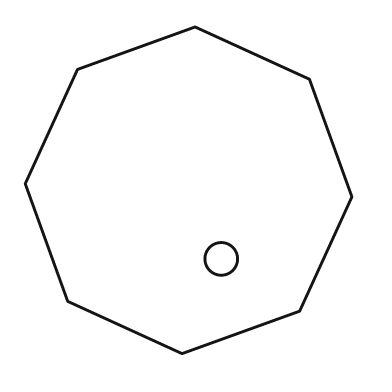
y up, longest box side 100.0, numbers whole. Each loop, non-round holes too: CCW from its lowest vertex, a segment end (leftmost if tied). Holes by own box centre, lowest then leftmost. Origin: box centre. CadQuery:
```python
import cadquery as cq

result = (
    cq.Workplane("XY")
    .moveTo(-2.0, -50.0)
    .lineTo(34.0, -37.0)
    .lineTo(50.0, -2.0)
    .lineTo(37.0, 34.0)
    .lineTo(2.0, 50.0)
    .lineTo(-34.0, 37.0)
    .lineTo(-50.0, 2.0)
    .lineTo(-37.0, -34.0)
    .close()
    .moveTo(10.0, -21.0)
    .circle(5.0)
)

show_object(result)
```